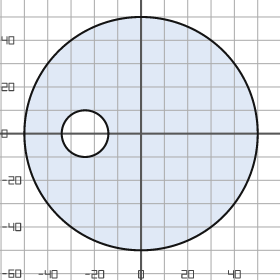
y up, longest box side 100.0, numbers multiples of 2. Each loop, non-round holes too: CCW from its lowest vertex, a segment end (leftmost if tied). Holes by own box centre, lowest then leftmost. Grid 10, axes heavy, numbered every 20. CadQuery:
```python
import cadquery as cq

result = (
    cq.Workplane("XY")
    .moveTo(0.0, 0.0)
    .circle(50.0)
    .moveTo(-24.0, 0.0)
    .circle(10.0)
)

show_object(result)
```